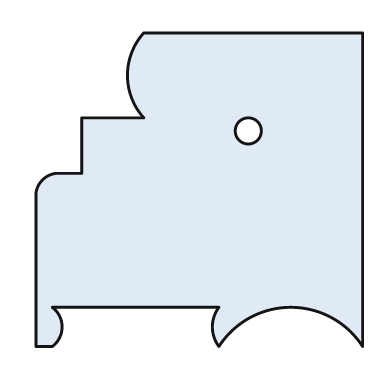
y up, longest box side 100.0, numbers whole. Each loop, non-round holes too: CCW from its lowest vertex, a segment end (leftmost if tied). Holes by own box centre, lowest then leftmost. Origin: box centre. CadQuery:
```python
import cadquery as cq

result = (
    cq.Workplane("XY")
    .moveTo(-50.0, -48.0)
    .lineTo(-45.0, -48.0)
    .threePointArc((-42.0, -42.0), (-45.0, -36.0))
    .lineTo(6.0, -36.0)
    .threePointArc((4.0, -42.0), (6.0, -48.0))
    .threePointArc((28.0, -36.0), (50.0, -48.0))
    .lineTo(50.0, 48.0)
    .lineTo(-17.0, 48.0)
    .threePointArc((-22.0, 35.0), (-17.0, 22.0))
    .lineTo(-36.0, 22.0)
    .lineTo(-36.0, 5.0)
    .lineTo(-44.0, 5.0)
    .threePointArc((-48.0, 3.0), (-50.0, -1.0))
    .close()
    .moveTo(15.0, 18.0)
    .circle(4.0)
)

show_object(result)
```